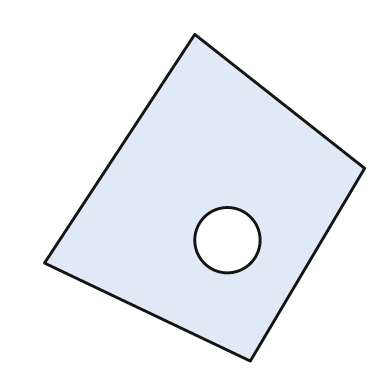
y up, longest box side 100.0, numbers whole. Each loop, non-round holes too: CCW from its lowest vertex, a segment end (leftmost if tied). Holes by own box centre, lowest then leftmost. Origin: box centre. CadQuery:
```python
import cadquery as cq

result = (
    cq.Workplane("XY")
    .moveTo(14.0, -50.0)
    .lineTo(49.0, 9.0)
    .lineTo(-3.0, 50.0)
    .lineTo(-49.0, -20.0)
    .close()
    .moveTo(7.0, -13.0)
    .circle(10.0)
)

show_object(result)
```